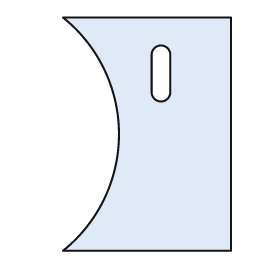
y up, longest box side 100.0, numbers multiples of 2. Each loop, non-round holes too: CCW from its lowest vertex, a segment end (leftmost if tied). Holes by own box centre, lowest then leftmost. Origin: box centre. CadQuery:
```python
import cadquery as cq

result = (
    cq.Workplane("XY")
    .moveTo(-36.0, -50.0)
    .lineTo(36.0, -50.0)
    .lineTo(36.0, 50.0)
    .lineTo(-36.0, 50.0)
    .threePointArc((-12.0, 0.0), (-36.0, -50.0))
    .close()
    .moveTo(2.0, 18.0)
    .threePointArc((6.0, 14.0), (10.0, 18.0))
    .lineTo(10.0, 34.0)
    .threePointArc((6.0, 38.0), (2.0, 34.0))
    .close()
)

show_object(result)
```